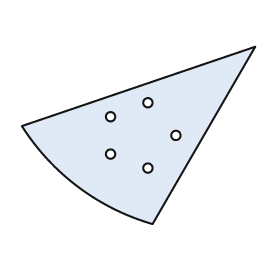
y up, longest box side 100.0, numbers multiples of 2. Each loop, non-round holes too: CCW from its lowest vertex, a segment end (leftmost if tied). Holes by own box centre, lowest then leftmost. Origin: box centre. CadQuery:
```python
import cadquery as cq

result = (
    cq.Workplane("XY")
    .moveTo(6.0, -38.0)
    .lineTo(50.0, 38.0)
    .lineTo(-50.0, 4.0)
    .threePointArc((-26.0, -22.0), (6.0, -38.0))
    .close()
    .moveTo(4.0, -14.0)
    .circle(2.0)
    .moveTo(-12.0, -8.0)
    .circle(2.0)
    .moveTo(16.0, 0.0)
    .circle(2.0)
    .moveTo(-12.0, 8.0)
    .circle(2.0)
    .moveTo(4.0, 14.0)
    .circle(2.0)
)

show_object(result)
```